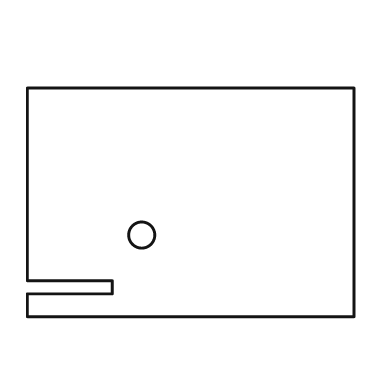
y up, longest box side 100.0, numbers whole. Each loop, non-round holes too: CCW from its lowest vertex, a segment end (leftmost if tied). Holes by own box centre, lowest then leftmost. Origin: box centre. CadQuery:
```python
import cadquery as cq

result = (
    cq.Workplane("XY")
    .moveTo(-50.0, -35.0)
    .lineTo(50.0, -35.0)
    .lineTo(50.0, 35.0)
    .lineTo(-50.0, 35.0)
    .lineTo(-50.0, -24.0)
    .lineTo(-24.0, -24.0)
    .lineTo(-24.0, -28.0)
    .lineTo(-50.0, -28.0)
    .close()
    .moveTo(-15.0, -10.0)
    .circle(4.0)
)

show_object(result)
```